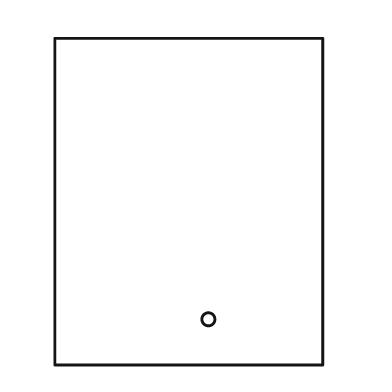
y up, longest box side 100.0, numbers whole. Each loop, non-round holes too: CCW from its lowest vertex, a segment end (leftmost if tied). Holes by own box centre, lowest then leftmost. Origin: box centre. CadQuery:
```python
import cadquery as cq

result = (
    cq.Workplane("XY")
    .moveTo(-41.0, -50.0)
    .lineTo(41.0, -50.0)
    .lineTo(41.0, 50.0)
    .lineTo(-41.0, 50.0)
    .close()
    .moveTo(6.0, -36.0)
    .circle(2.0)
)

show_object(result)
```